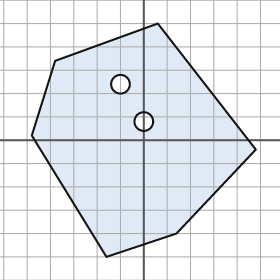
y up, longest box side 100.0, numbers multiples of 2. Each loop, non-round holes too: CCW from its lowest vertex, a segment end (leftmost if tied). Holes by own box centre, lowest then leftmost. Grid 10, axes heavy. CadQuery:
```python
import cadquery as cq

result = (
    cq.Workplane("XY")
    .moveTo(-16.0, -50.0)
    .lineTo(14.0, -40.0)
    .lineTo(48.0, -4.0)
    .lineTo(6.0, 50.0)
    .lineTo(-38.0, 34.0)
    .lineTo(-48.0, 2.0)
    .close()
    .moveTo(0.0, 8.0)
    .circle(4.0)
    .moveTo(-10.0, 24.0)
    .circle(4.0)
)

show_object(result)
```